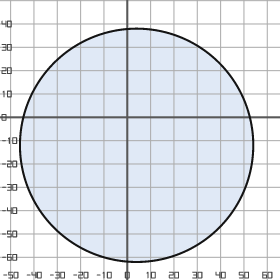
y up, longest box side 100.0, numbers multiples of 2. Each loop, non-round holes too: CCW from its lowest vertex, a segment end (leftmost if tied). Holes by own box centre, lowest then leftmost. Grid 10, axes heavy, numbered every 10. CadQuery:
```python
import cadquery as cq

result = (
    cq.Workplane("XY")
    .moveTo(4.0, -12.0)
    .circle(50.0)
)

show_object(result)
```